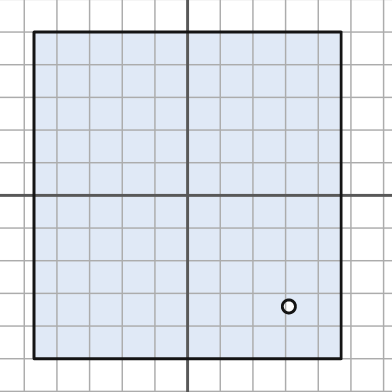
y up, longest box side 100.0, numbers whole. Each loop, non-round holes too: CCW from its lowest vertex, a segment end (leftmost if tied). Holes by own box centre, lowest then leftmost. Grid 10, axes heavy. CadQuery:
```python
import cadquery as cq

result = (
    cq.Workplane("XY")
    .moveTo(-47.0, -50.0)
    .lineTo(47.0, -50.0)
    .lineTo(47.0, 50.0)
    .lineTo(-47.0, 50.0)
    .close()
    .moveTo(31.0, -34.0)
    .circle(2.0)
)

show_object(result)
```